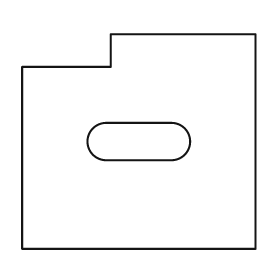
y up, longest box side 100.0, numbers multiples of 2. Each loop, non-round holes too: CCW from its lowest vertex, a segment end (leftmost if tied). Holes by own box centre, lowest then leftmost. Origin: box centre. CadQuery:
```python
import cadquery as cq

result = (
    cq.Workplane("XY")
    .moveTo(-50.0, -46.0)
    .lineTo(50.0, -46.0)
    .lineTo(50.0, 46.0)
    .lineTo(-12.0, 46.0)
    .lineTo(-12.0, 32.0)
    .lineTo(-50.0, 32.0)
    .close()
    .moveTo(-14.0, -8.0)
    .lineTo(14.0, -8.0)
    .threePointArc((22.0, 0.0), (14.0, 8.0))
    .lineTo(-14.0, 8.0)
    .threePointArc((-22.0, 0.0), (-14.0, -8.0))
    .close()
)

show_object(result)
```